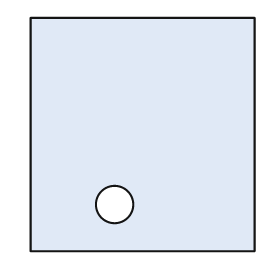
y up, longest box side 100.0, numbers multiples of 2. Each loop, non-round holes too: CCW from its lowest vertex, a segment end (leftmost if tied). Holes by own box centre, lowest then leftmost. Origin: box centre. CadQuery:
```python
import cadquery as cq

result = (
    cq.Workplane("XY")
    .moveTo(-48.0, -50.0)
    .lineTo(48.0, -50.0)
    .lineTo(48.0, 50.0)
    .lineTo(-48.0, 50.0)
    .close()
    .moveTo(-12.0, -30.0)
    .circle(8.0)
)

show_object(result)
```